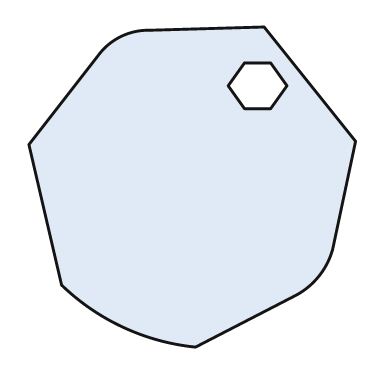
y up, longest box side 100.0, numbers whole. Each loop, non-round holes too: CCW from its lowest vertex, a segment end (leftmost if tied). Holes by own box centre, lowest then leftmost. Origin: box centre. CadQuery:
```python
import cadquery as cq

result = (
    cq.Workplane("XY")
    .moveTo(1.0, -49.0)
    .lineTo(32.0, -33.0)
    .threePointArc((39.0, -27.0), (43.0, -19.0))
    .lineTo(50.0, 14.0)
    .lineTo(22.0, 49.0)
    .lineTo(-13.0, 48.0)
    .threePointArc((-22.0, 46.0), (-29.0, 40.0))
    .lineTo(-50.0, 13.0)
    .lineTo(-40.0, -30.0)
    .threePointArc((-21.0, -43.0), (1.0, -49.0))
    .close()
    .moveTo(16.0, 24.0)
    .lineTo(24.0, 24.0)
    .lineTo(29.0, 31.0)
    .lineTo(24.0, 38.0)
    .lineTo(16.0, 38.0)
    .lineTo(11.0, 31.0)
    .close()
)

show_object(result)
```